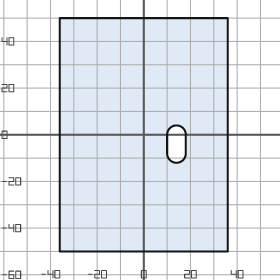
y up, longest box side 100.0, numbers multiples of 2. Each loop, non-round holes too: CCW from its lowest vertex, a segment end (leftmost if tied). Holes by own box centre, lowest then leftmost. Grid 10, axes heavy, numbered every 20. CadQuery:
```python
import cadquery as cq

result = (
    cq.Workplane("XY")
    .moveTo(-36.0, -50.0)
    .lineTo(36.0, -50.0)
    .lineTo(36.0, 50.0)
    .lineTo(-36.0, 50.0)
    .close()
    .moveTo(10.0, -8.0)
    .threePointArc((14.0, -12.0), (18.0, -8.0))
    .lineTo(18.0, 0.0)
    .threePointArc((14.0, 4.0), (10.0, 0.0))
    .close()
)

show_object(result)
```